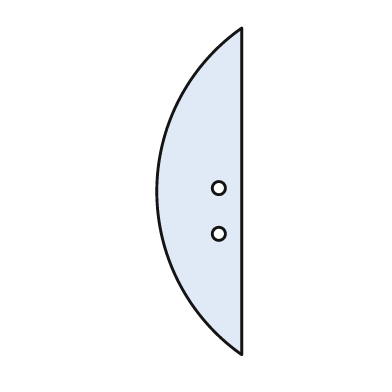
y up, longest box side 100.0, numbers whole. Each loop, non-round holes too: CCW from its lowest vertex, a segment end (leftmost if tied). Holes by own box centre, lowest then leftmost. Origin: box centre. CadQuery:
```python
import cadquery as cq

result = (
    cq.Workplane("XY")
    .moveTo(13.0, -50.0)
    .lineTo(13.0, 50.0)
    .threePointArc((-13.0, 0.0), (13.0, -50.0))
    .close()
    .moveTo(6.0, -13.0)
    .circle(2.0)
    .moveTo(6.0, 1.0)
    .circle(2.0)
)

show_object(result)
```